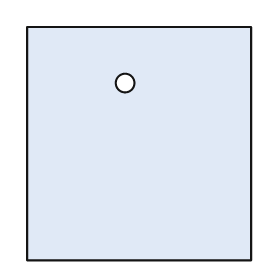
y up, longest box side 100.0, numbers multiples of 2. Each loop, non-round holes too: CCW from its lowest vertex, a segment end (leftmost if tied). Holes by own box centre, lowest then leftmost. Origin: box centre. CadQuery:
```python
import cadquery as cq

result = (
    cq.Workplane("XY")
    .moveTo(-48.0, -50.0)
    .lineTo(48.0, -50.0)
    .lineTo(48.0, 50.0)
    .lineTo(-48.0, 50.0)
    .close()
    .moveTo(-6.0, 26.0)
    .circle(4.0)
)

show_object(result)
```